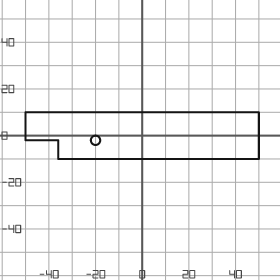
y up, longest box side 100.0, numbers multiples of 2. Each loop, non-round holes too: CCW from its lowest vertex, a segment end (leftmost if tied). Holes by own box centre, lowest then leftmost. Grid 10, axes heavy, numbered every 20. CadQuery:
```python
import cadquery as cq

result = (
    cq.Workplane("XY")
    .moveTo(-36.0, -10.0)
    .lineTo(50.0, -10.0)
    .lineTo(50.0, 10.0)
    .lineTo(-50.0, 10.0)
    .lineTo(-50.0, -2.0)
    .lineTo(-36.0, -2.0)
    .close()
    .moveTo(-20.0, -2.0)
    .circle(2.0)
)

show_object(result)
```